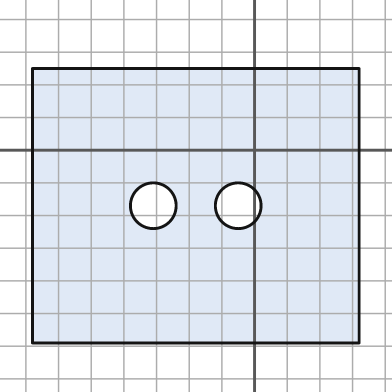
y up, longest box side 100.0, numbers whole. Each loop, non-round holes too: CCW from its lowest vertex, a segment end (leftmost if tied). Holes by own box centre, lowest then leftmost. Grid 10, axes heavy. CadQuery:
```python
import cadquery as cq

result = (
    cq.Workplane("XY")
    .moveTo(-68.0, -59.0)
    .lineTo(32.0, -59.0)
    .lineTo(32.0, 25.0)
    .lineTo(-68.0, 25.0)
    .close()
    .moveTo(-31.0, -17.0)
    .circle(7.0)
    .moveTo(-5.0, -17.0)
    .circle(7.0)
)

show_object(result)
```